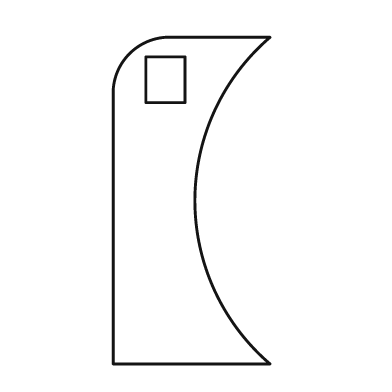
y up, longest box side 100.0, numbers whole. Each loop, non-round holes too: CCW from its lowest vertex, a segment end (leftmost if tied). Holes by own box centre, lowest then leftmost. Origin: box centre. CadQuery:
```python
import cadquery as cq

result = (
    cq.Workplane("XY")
    .moveTo(-24.0, -50.0)
    .lineTo(24.0, -50.0)
    .threePointArc((1.0, 0.0), (24.0, 50.0))
    .lineTo(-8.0, 50.0)
    .threePointArc((-19.0, 45.0), (-24.0, 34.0))
    .close()
    .moveTo(-14.0, 30.0)
    .lineTo(-2.0, 30.0)
    .lineTo(-2.0, 44.0)
    .lineTo(-14.0, 44.0)
    .close()
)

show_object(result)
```